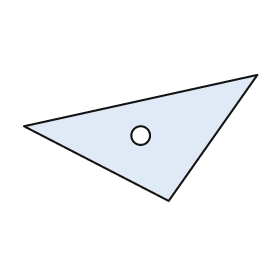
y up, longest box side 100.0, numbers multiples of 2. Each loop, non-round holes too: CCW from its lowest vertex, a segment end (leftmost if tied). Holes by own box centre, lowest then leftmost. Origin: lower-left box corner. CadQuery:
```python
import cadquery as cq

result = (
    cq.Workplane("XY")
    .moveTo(62.0, 0.0)
    .lineTo(100.0, 54.0)
    .lineTo(0.0, 32.0)
    .close()
    .moveTo(50.0, 28.0)
    .circle(4.0)
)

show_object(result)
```